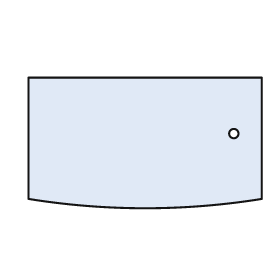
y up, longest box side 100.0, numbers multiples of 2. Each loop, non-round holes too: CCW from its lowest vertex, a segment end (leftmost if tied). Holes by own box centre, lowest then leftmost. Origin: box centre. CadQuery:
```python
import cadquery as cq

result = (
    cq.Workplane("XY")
    .moveTo(-50.0, -24.0)
    .threePointArc((0.0, -28.0), (50.0, -24.0))
    .lineTo(50.0, 28.0)
    .lineTo(-50.0, 28.0)
    .close()
    .moveTo(38.0, 4.0)
    .circle(2.0)
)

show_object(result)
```